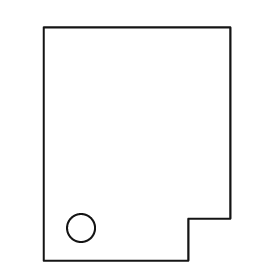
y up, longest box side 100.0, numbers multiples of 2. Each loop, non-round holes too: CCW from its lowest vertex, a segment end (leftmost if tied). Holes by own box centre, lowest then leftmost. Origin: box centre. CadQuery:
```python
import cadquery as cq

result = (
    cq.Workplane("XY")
    .moveTo(-40.0, -50.0)
    .lineTo(22.0, -50.0)
    .lineTo(22.0, -32.0)
    .lineTo(40.0, -32.0)
    .lineTo(40.0, 50.0)
    .lineTo(-40.0, 50.0)
    .close()
    .moveTo(-24.0, -36.0)
    .circle(6.0)
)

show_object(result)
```